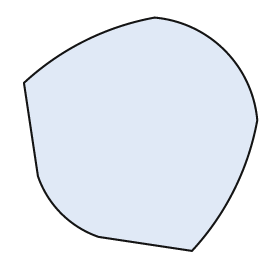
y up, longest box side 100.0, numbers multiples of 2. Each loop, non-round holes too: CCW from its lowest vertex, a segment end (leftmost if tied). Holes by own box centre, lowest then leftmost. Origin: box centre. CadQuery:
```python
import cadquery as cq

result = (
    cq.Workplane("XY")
    .moveTo(22.0, -50.0)
    .threePointArc((40.0, -24.0), (50.0, 6.0))
    .threePointArc((36.0, 36.0), (6.0, 50.0))
    .threePointArc((-24.0, 40.0), (-50.0, 22.0))
    .lineTo(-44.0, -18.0)
    .threePointArc((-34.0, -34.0), (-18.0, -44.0))
    .close()
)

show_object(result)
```